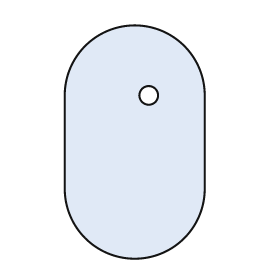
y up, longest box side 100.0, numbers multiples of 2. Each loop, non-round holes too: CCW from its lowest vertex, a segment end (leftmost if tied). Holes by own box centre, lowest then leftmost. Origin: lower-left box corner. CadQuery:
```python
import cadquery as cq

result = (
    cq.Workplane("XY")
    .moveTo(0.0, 30.0)
    .threePointArc((30.0, 0.0), (60.0, 30.0))
    .lineTo(60.0, 70.0)
    .threePointArc((30.0, 100.0), (0.0, 70.0))
    .close()
    .moveTo(36.0, 70.0)
    .circle(4.0)
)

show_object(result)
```